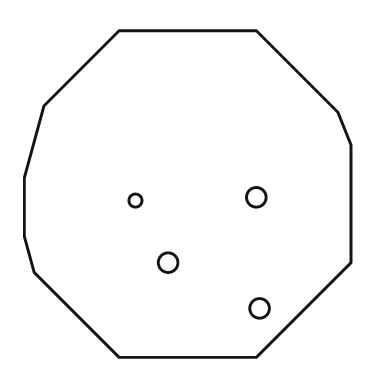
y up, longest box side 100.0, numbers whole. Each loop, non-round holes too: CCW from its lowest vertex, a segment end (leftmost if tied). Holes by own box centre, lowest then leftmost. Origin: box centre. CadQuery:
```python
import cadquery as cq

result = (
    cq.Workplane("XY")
    .moveTo(-21.0, -50.0)
    .lineTo(21.0, -50.0)
    .lineTo(50.0, -21.0)
    .lineTo(50.0, 15.0)
    .lineTo(46.0, 25.0)
    .lineTo(21.0, 50.0)
    .lineTo(-21.0, 50.0)
    .lineTo(-44.0, 27.0)
    .lineTo(-50.0, 5.0)
    .lineTo(-50.0, -13.0)
    .lineTo(-47.0, -24.0)
    .close()
    .moveTo(22.0, -35.0)
    .circle(3.0)
    .moveTo(-6.0, -21.0)
    .circle(3.0)
    .moveTo(-16.0, -2.0)
    .circle(2.0)
    .moveTo(21.0, -1.0)
    .circle(3.0)
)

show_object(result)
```